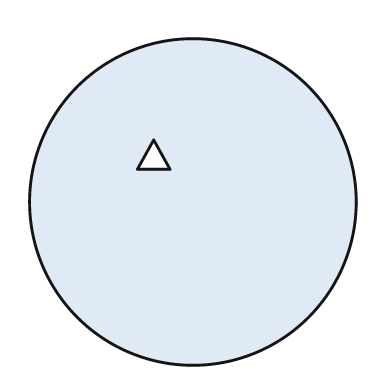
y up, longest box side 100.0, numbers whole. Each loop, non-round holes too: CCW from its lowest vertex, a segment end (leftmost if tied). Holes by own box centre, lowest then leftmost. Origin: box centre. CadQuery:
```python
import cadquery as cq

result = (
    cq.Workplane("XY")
    .moveTo(0.0, 0.0)
    .circle(50.0)
    .moveTo(-17.0, 10.0)
    .lineTo(-7.0, 10.0)
    .lineTo(-12.0, 19.0)
    .close()
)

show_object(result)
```